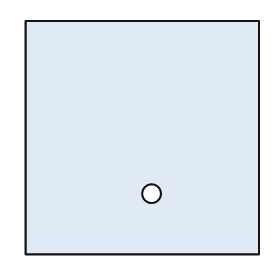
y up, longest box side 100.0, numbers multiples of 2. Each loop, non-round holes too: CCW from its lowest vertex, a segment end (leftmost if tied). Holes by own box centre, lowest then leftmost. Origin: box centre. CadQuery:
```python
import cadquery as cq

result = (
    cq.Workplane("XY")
    .moveTo(-50.0, -50.0)
    .lineTo(50.0, -50.0)
    .lineTo(50.0, 50.0)
    .lineTo(-50.0, 50.0)
    .close()
    .moveTo(4.0, -24.0)
    .circle(4.0)
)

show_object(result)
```